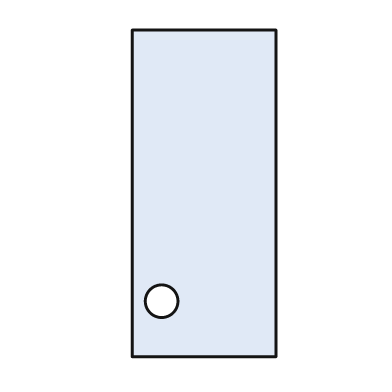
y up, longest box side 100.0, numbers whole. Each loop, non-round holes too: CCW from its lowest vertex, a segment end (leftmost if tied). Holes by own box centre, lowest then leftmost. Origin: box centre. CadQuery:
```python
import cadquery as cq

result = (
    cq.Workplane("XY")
    .moveTo(-22.0, -50.0)
    .lineTo(22.0, -50.0)
    .lineTo(22.0, 50.0)
    .lineTo(-22.0, 50.0)
    .close()
    .moveTo(-13.0, -33.0)
    .circle(5.0)
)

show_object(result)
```